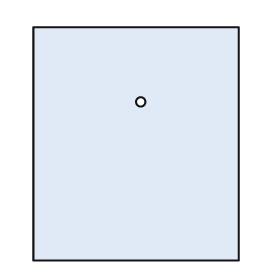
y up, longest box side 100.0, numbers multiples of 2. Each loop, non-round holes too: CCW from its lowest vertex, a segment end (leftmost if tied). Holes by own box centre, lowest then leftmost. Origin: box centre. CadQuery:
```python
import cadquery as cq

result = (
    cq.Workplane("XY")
    .moveTo(-44.0, -50.0)
    .lineTo(44.0, -50.0)
    .lineTo(44.0, 50.0)
    .lineTo(-44.0, 50.0)
    .close()
    .moveTo(2.0, 18.0)
    .circle(2.0)
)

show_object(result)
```